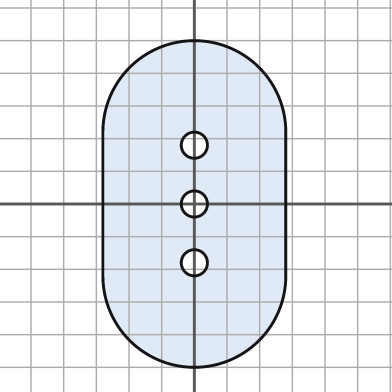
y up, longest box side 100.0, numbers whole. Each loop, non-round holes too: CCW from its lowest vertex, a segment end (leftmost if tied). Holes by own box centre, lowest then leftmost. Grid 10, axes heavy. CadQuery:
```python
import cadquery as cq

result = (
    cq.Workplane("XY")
    .moveTo(-28.0, -22.0)
    .threePointArc((0.0, -50.0), (28.0, -22.0))
    .lineTo(28.0, 22.0)
    .threePointArc((0.0, 50.0), (-28.0, 22.0))
    .close()
    .moveTo(0.0, -18.0)
    .circle(4.0)
    .moveTo(0.0, 0.0)
    .circle(4.0)
    .moveTo(0.0, 18.0)
    .circle(4.0)
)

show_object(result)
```